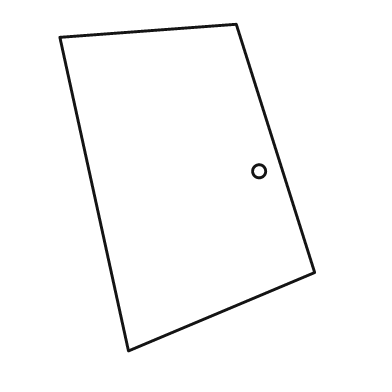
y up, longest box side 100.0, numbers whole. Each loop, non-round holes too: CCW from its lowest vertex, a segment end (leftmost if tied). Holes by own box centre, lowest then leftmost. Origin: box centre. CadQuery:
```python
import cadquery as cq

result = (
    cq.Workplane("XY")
    .moveTo(-18.0, -50.0)
    .lineTo(39.0, -26.0)
    .lineTo(15.0, 50.0)
    .lineTo(-39.0, 46.0)
    .close()
    .moveTo(22.0, 5.0)
    .circle(2.0)
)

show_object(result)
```